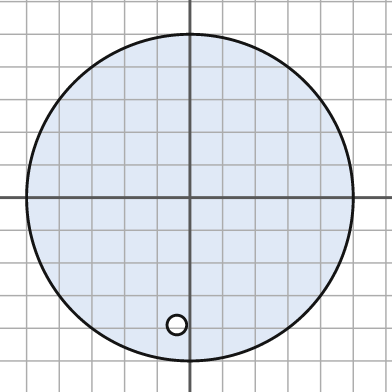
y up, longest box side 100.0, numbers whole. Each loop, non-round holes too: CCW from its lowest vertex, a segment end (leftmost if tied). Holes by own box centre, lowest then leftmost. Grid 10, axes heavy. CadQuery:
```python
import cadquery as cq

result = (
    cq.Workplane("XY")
    .moveTo(0.0, 0.0)
    .circle(50.0)
    .moveTo(-4.0, -39.0)
    .circle(3.0)
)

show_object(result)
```